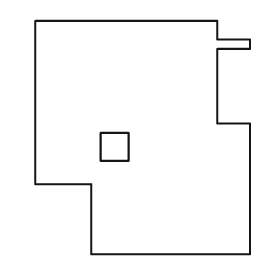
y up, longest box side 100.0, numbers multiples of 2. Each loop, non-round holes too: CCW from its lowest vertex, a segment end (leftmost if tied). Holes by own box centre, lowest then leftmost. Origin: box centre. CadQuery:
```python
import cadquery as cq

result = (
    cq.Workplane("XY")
    .moveTo(-22.0, -50.0)
    .lineTo(46.0, -50.0)
    .lineTo(46.0, 6.0)
    .lineTo(32.0, 6.0)
    .lineTo(32.0, 38.0)
    .lineTo(46.0, 38.0)
    .lineTo(46.0, 42.0)
    .lineTo(32.0, 42.0)
    .lineTo(32.0, 50.0)
    .lineTo(-46.0, 50.0)
    .lineTo(-46.0, -20.0)
    .lineTo(-22.0, -20.0)
    .close()
    .moveTo(-18.0, -10.0)
    .lineTo(-6.0, -10.0)
    .lineTo(-6.0, 2.0)
    .lineTo(-18.0, 2.0)
    .close()
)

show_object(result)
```